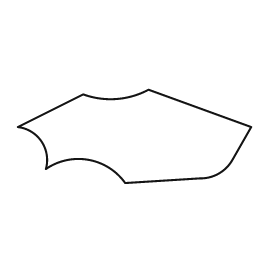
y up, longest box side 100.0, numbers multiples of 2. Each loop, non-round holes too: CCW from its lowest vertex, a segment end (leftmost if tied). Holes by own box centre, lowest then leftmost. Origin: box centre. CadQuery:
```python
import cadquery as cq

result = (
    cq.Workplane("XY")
    .moveTo(-4.0, -20.0)
    .lineTo(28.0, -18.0)
    .threePointArc((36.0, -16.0), (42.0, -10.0))
    .lineTo(50.0, 4.0)
    .lineTo(6.0, 20.0)
    .threePointArc((-8.0, 16.0), (-22.0, 18.0))
    .lineTo(-50.0, 4.0)
    .threePointArc((-40.0, -2.0), (-38.0, -14.0))
    .threePointArc((-20.0, -10.0), (-4.0, -20.0))
    .close()
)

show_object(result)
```